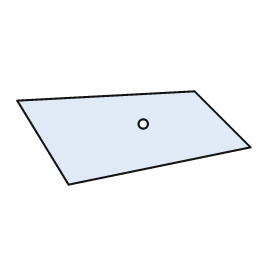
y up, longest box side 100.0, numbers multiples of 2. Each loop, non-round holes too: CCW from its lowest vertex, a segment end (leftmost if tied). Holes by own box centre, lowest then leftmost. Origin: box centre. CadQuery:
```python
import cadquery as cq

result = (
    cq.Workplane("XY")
    .moveTo(-28.0, -20.0)
    .lineTo(50.0, -4.0)
    .lineTo(26.0, 20.0)
    .lineTo(-50.0, 16.0)
    .close()
    .moveTo(4.0, 6.0)
    .circle(2.0)
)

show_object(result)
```